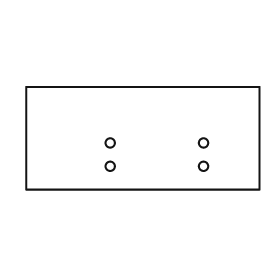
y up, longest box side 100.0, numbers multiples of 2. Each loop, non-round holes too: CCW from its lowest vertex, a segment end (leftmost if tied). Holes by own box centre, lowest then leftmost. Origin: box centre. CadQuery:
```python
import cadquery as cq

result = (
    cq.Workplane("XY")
    .moveTo(-50.0, -22.0)
    .lineTo(50.0, -22.0)
    .lineTo(50.0, 22.0)
    .lineTo(-50.0, 22.0)
    .close()
    .moveTo(-14.0, -12.0)
    .circle(2.0)
    .moveTo(26.0, -12.0)
    .circle(2.0)
    .moveTo(-14.0, -2.0)
    .circle(2.0)
    .moveTo(26.0, -2.0)
    .circle(2.0)
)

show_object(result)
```